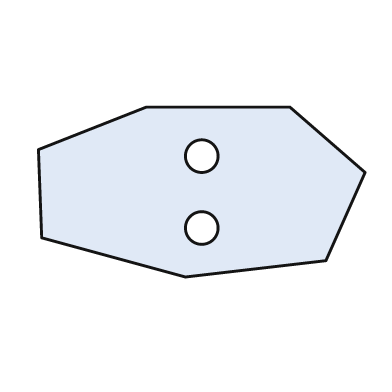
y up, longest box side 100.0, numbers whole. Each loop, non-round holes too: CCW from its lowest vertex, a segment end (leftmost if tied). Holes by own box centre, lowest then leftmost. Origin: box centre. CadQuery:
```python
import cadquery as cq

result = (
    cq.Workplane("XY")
    .moveTo(-5.0, -26.0)
    .lineTo(38.0, -21.0)
    .lineTo(50.0, 6.0)
    .lineTo(27.0, 26.0)
    .lineTo(-17.0, 26.0)
    .lineTo(-50.0, 13.0)
    .lineTo(-49.0, -14.0)
    .close()
    .moveTo(0.0, -11.0)
    .circle(5.0)
    .moveTo(0.0, 11.0)
    .circle(5.0)
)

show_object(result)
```